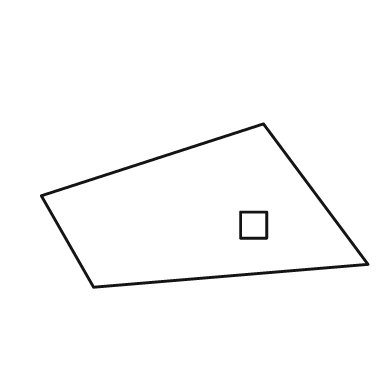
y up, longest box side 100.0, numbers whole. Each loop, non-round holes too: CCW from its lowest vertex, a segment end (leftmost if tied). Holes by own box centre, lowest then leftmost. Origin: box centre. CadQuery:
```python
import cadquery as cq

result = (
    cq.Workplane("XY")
    .moveTo(-34.0, -25.0)
    .lineTo(50.0, -18.0)
    .lineTo(18.0, 25.0)
    .lineTo(-50.0, 3.0)
    .close()
    .moveTo(11.0, -10.0)
    .lineTo(19.0, -10.0)
    .lineTo(19.0, -2.0)
    .lineTo(11.0, -2.0)
    .close()
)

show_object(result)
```